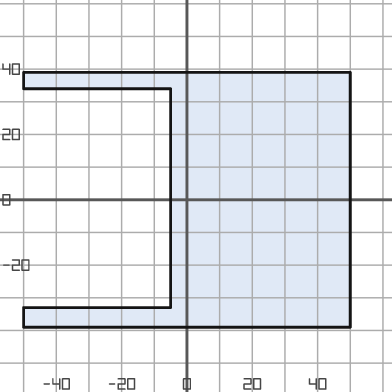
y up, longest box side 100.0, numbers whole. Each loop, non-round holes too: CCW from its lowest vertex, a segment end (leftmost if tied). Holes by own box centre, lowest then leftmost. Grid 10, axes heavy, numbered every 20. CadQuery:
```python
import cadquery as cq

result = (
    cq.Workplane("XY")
    .moveTo(-50.0, -39.0)
    .lineTo(50.0, -39.0)
    .lineTo(50.0, 39.0)
    .lineTo(-50.0, 39.0)
    .lineTo(-50.0, 34.0)
    .lineTo(-5.0, 34.0)
    .lineTo(-5.0, -33.0)
    .lineTo(-50.0, -33.0)
    .close()
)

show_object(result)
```